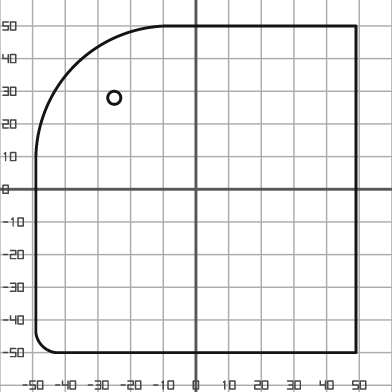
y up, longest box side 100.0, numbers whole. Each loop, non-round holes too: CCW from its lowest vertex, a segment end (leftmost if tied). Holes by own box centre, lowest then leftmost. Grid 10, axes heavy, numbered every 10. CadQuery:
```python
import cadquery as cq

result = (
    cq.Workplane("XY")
    .moveTo(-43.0, -50.0)
    .lineTo(49.0, -50.0)
    .lineTo(49.0, 50.0)
    .lineTo(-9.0, 50.0)
    .threePointArc((-37.0, 38.0), (-49.0, 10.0))
    .lineTo(-49.0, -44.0)
    .threePointArc((-47.0, -48.0), (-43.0, -50.0))
    .close()
    .moveTo(-25.0, 28.0)
    .circle(2.0)
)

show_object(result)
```